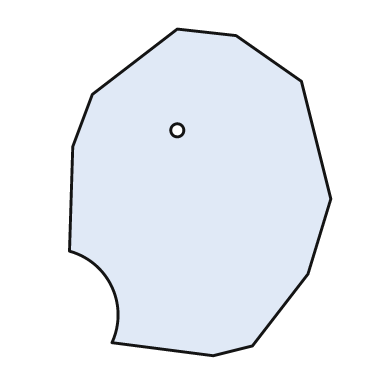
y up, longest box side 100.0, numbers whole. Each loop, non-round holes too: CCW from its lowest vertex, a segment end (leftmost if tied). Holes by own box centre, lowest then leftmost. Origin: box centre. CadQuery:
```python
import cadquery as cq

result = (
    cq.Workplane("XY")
    .moveTo(4.0, -50.0)
    .lineTo(16.0, -47.0)
    .lineTo(33.0, -25.0)
    .lineTo(40.0, -2.0)
    .lineTo(31.0, 34.0)
    .lineTo(11.0, 48.0)
    .lineTo(-7.0, 50.0)
    .lineTo(-33.0, 30.0)
    .lineTo(-39.0, 14.0)
    .lineTo(-40.0, -18.0)
    .threePointArc((-27.0, -29.0), (-27.0, -46.0))
    .close()
    .moveTo(-7.0, 19.0)
    .circle(2.0)
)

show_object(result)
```